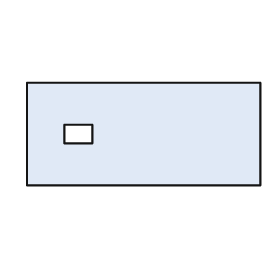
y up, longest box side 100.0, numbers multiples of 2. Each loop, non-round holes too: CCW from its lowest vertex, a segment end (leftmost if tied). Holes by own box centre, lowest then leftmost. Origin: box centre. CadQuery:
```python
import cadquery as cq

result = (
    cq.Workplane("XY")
    .moveTo(-50.0, -22.0)
    .lineTo(50.0, -22.0)
    .lineTo(50.0, 22.0)
    .lineTo(-50.0, 22.0)
    .close()
    .moveTo(-34.0, -4.0)
    .lineTo(-22.0, -4.0)
    .lineTo(-22.0, 4.0)
    .lineTo(-34.0, 4.0)
    .close()
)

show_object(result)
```